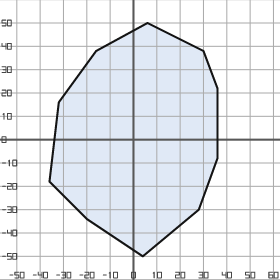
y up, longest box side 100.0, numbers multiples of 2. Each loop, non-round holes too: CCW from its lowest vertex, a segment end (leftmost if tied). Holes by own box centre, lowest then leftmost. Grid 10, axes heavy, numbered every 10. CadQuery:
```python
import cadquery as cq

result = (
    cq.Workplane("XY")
    .moveTo(4.0, -50.0)
    .lineTo(28.0, -30.0)
    .lineTo(36.0, -8.0)
    .lineTo(36.0, 22.0)
    .lineTo(30.0, 38.0)
    .lineTo(6.0, 50.0)
    .lineTo(-16.0, 38.0)
    .lineTo(-32.0, 16.0)
    .lineTo(-36.0, -18.0)
    .lineTo(-20.0, -34.0)
    .close()
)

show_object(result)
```